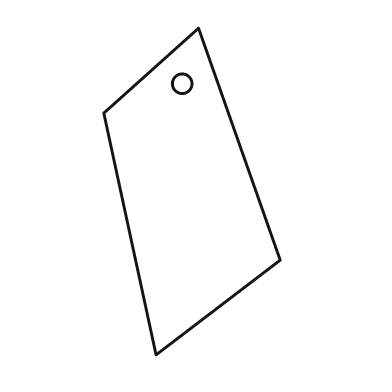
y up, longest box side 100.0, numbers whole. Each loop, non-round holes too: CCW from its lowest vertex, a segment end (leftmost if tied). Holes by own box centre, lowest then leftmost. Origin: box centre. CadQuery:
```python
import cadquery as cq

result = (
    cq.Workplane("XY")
    .moveTo(-11.0, -50.0)
    .lineTo(27.0, -21.0)
    .lineTo(2.0, 50.0)
    .lineTo(-27.0, 24.0)
    .close()
    .moveTo(-3.0, 33.0)
    .circle(3.0)
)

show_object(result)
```